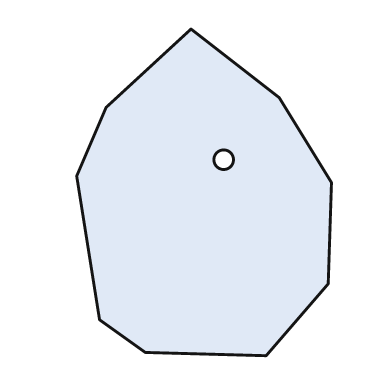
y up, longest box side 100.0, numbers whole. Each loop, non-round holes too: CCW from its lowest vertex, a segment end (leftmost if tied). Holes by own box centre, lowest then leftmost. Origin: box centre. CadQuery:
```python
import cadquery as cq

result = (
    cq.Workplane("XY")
    .moveTo(19.0, -50.0)
    .lineTo(38.0, -28.0)
    .lineTo(39.0, 3.0)
    .lineTo(23.0, 29.0)
    .lineTo(-4.0, 50.0)
    .lineTo(-30.0, 26.0)
    .lineTo(-39.0, 5.0)
    .lineTo(-32.0, -39.0)
    .lineTo(-18.0, -49.0)
    .close()
    .moveTo(6.0, 10.0)
    .circle(3.0)
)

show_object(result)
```